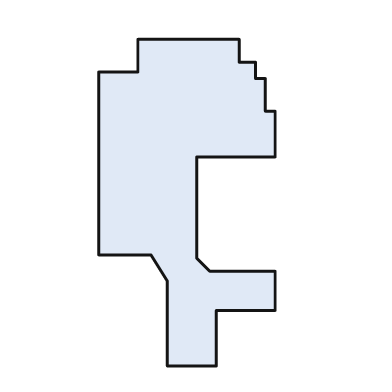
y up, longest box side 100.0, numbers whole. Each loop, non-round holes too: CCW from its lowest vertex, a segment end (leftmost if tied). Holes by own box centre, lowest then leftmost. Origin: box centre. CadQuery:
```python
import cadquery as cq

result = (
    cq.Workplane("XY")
    .moveTo(-6.0, -50.0)
    .lineTo(9.0, -50.0)
    .lineTo(9.0, -33.0)
    .lineTo(27.0, -33.0)
    .lineTo(27.0, -21.0)
    .lineTo(7.0, -21.0)
    .lineTo(3.0, -17.0)
    .lineTo(3.0, 14.0)
    .lineTo(27.0, 14.0)
    .lineTo(27.0, 28.0)
    .lineTo(24.0, 28.0)
    .lineTo(24.0, 38.0)
    .lineTo(21.0, 38.0)
    .lineTo(21.0, 43.0)
    .lineTo(16.0, 43.0)
    .lineTo(16.0, 50.0)
    .lineTo(-15.0, 50.0)
    .lineTo(-15.0, 40.0)
    .lineTo(-27.0, 40.0)
    .lineTo(-27.0, -16.0)
    .lineTo(-11.0, -16.0)
    .lineTo(-6.0, -24.0)
    .close()
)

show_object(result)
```